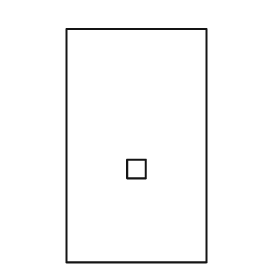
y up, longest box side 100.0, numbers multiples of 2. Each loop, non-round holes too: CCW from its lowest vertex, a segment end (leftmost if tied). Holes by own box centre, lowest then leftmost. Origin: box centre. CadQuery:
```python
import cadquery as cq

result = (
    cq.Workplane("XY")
    .moveTo(-30.0, -50.0)
    .lineTo(30.0, -50.0)
    .lineTo(30.0, 50.0)
    .lineTo(-30.0, 50.0)
    .close()
    .moveTo(-4.0, -14.0)
    .lineTo(4.0, -14.0)
    .lineTo(4.0, -6.0)
    .lineTo(-4.0, -6.0)
    .close()
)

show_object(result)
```